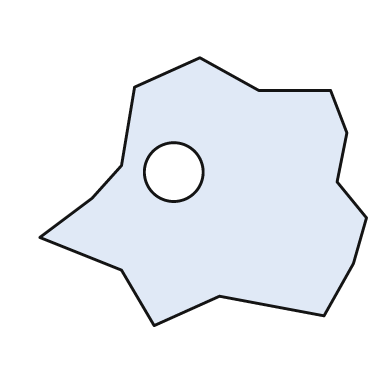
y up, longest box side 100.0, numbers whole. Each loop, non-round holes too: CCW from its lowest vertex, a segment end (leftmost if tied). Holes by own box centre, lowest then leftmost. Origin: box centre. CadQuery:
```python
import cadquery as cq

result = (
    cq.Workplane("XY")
    .moveTo(-15.0, -41.0)
    .lineTo(5.0, -32.0)
    .lineTo(37.0, -38.0)
    .lineTo(46.0, -22.0)
    .lineTo(50.0, -8.0)
    .lineTo(41.0, 3.0)
    .lineTo(44.0, 18.0)
    .lineTo(39.0, 31.0)
    .lineTo(17.0, 31.0)
    .lineTo(-1.0, 41.0)
    .lineTo(-21.0, 32.0)
    .lineTo(-25.0, 8.0)
    .lineTo(-34.0, -2.0)
    .lineTo(-50.0, -14.0)
    .lineTo(-25.0, -24.0)
    .close()
    .moveTo(-9.0, 6.0)
    .circle(9.0)
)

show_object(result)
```